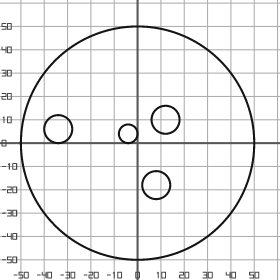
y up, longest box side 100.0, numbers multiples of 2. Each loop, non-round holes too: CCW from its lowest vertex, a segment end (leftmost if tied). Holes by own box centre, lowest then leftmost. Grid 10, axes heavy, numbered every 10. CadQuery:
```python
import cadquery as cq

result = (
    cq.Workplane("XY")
    .moveTo(0.0, 0.0)
    .circle(50.0)
    .moveTo(8.0, -18.0)
    .circle(6.0)
    .moveTo(-4.0, 4.0)
    .circle(4.0)
    .moveTo(-34.0, 6.0)
    .circle(6.0)
    .moveTo(12.0, 10.0)
    .circle(6.0)
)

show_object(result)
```